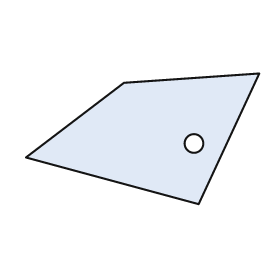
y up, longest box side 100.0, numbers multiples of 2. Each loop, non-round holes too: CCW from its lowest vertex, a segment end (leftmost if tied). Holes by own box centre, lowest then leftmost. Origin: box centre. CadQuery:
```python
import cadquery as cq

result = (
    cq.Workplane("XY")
    .moveTo(24.0, -28.0)
    .lineTo(50.0, 28.0)
    .lineTo(-8.0, 24.0)
    .lineTo(-50.0, -8.0)
    .close()
    .moveTo(22.0, -2.0)
    .circle(4.0)
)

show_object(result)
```